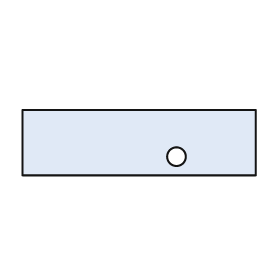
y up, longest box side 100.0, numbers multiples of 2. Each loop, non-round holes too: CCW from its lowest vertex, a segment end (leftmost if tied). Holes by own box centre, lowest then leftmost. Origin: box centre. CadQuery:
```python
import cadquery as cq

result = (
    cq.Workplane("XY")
    .moveTo(-50.0, -14.0)
    .lineTo(50.0, -14.0)
    .lineTo(50.0, 14.0)
    .lineTo(-50.0, 14.0)
    .close()
    .moveTo(16.0, -6.0)
    .circle(4.0)
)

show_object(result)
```